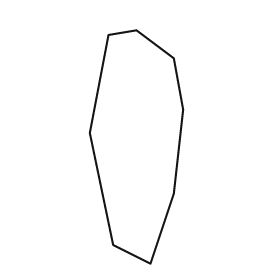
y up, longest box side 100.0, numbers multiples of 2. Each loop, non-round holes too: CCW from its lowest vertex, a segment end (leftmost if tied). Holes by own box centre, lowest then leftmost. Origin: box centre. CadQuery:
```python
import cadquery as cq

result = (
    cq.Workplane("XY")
    .moveTo(6.0, -50.0)
    .lineTo(16.0, -20.0)
    .lineTo(20.0, 16.0)
    .lineTo(16.0, 38.0)
    .lineTo(0.0, 50.0)
    .lineTo(-12.0, 48.0)
    .lineTo(-20.0, 6.0)
    .lineTo(-10.0, -42.0)
    .close()
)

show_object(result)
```